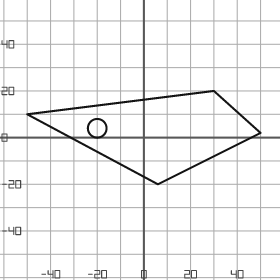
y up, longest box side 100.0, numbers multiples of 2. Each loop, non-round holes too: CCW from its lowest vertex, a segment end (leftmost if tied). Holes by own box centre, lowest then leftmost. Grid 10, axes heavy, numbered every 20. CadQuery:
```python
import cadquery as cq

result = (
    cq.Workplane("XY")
    .moveTo(6.0, -20.0)
    .lineTo(50.0, 2.0)
    .lineTo(30.0, 20.0)
    .lineTo(-50.0, 10.0)
    .close()
    .moveTo(-20.0, 4.0)
    .circle(4.0)
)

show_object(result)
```